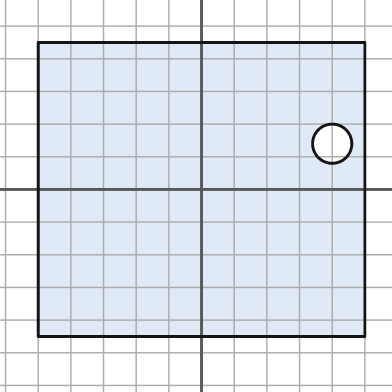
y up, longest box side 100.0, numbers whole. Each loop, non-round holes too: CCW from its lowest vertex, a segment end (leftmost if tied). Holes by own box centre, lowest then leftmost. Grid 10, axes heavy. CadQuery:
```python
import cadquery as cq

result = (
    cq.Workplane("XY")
    .moveTo(-50.0, -45.0)
    .lineTo(50.0, -45.0)
    .lineTo(50.0, 45.0)
    .lineTo(-50.0, 45.0)
    .close()
    .moveTo(40.0, 14.0)
    .circle(6.0)
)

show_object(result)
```